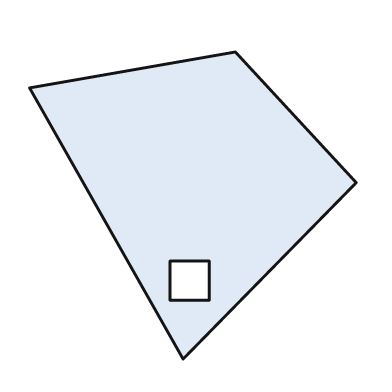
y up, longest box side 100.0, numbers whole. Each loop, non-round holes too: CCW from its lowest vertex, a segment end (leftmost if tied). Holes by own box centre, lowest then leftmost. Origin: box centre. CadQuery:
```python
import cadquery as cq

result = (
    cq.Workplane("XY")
    .moveTo(-3.0, -47.0)
    .lineTo(50.0, 7.0)
    .lineTo(13.0, 47.0)
    .lineTo(-50.0, 36.0)
    .close()
    .moveTo(-7.0, -29.0)
    .lineTo(5.0, -29.0)
    .lineTo(5.0, -17.0)
    .lineTo(-7.0, -17.0)
    .close()
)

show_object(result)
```